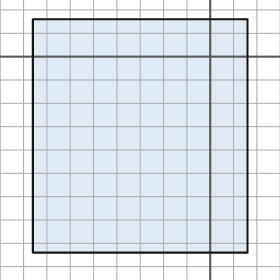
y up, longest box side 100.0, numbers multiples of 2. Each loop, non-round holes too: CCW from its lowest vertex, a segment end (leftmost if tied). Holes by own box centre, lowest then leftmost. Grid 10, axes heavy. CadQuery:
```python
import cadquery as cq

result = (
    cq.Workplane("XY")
    .moveTo(-76.0, -84.0)
    .lineTo(16.0, -84.0)
    .lineTo(16.0, 16.0)
    .lineTo(-76.0, 16.0)
    .close()
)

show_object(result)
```